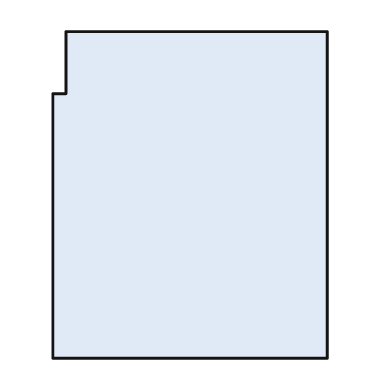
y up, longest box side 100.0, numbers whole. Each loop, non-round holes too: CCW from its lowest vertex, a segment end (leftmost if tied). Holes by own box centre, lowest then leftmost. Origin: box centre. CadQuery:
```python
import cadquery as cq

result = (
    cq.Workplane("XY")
    .moveTo(-42.0, -50.0)
    .lineTo(42.0, -50.0)
    .lineTo(42.0, 50.0)
    .lineTo(-38.0, 50.0)
    .lineTo(-38.0, 31.0)
    .lineTo(-42.0, 31.0)
    .close()
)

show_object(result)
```